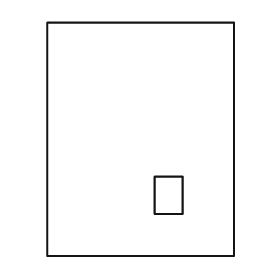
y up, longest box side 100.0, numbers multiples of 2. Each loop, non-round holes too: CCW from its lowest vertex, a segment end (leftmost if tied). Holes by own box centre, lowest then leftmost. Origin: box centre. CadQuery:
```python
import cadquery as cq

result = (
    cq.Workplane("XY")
    .moveTo(-40.0, -50.0)
    .lineTo(40.0, -50.0)
    .lineTo(40.0, 50.0)
    .lineTo(-40.0, 50.0)
    .close()
    .moveTo(6.0, -32.0)
    .lineTo(18.0, -32.0)
    .lineTo(18.0, -16.0)
    .lineTo(6.0, -16.0)
    .close()
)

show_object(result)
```